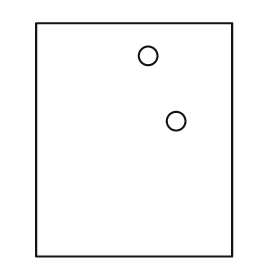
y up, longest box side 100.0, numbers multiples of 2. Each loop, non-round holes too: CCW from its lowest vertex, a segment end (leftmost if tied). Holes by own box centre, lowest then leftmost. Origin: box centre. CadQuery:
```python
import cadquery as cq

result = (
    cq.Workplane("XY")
    .moveTo(-42.0, -50.0)
    .lineTo(42.0, -50.0)
    .lineTo(42.0, 50.0)
    .lineTo(-42.0, 50.0)
    .close()
    .moveTo(18.0, 8.0)
    .circle(4.0)
    .moveTo(6.0, 36.0)
    .circle(4.0)
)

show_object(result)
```